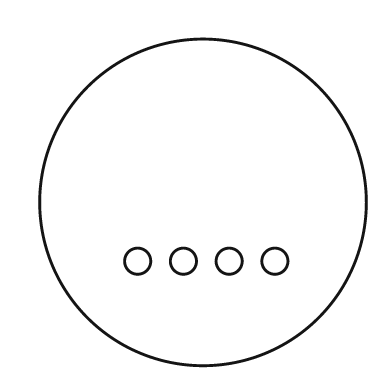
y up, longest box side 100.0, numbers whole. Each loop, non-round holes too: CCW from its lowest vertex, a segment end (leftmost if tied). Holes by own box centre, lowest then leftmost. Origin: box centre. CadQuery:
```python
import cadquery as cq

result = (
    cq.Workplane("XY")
    .moveTo(0.0, 0.0)
    .circle(50.0)
    .moveTo(-20.0, -18.0)
    .circle(4.0)
    .moveTo(-6.0, -18.0)
    .circle(4.0)
    .moveTo(8.0, -18.0)
    .circle(4.0)
    .moveTo(22.0, -18.0)
    .circle(4.0)
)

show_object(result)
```